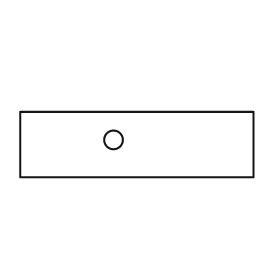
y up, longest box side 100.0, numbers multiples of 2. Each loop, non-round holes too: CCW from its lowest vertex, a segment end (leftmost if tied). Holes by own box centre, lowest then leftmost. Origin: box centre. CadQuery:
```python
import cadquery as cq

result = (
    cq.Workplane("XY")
    .moveTo(-50.0, -14.0)
    .lineTo(50.0, -14.0)
    .lineTo(50.0, 14.0)
    .lineTo(-50.0, 14.0)
    .close()
    .moveTo(-10.0, 2.0)
    .circle(4.0)
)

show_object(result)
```